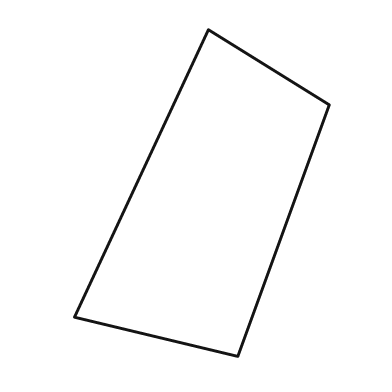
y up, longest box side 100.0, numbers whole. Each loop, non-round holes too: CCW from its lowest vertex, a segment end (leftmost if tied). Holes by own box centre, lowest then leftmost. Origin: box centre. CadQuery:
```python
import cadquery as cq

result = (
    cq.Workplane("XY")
    .moveTo(11.0, -50.0)
    .lineTo(39.0, 27.0)
    .lineTo(2.0, 50.0)
    .lineTo(-39.0, -38.0)
    .close()
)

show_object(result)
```